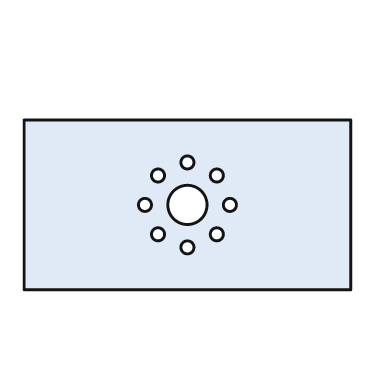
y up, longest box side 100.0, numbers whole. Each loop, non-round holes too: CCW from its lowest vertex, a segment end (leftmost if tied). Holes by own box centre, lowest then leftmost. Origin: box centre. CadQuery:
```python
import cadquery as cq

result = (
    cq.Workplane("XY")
    .moveTo(-50.0, -26.0)
    .lineTo(50.0, -26.0)
    .lineTo(50.0, 26.0)
    .lineTo(-50.0, 26.0)
    .close()
    .moveTo(0.0, -13.0)
    .circle(2.0)
    .moveTo(-9.0, -9.0)
    .circle(2.0)
    .moveTo(9.0, -9.0)
    .circle(2.0)
    .moveTo(-13.0, 0.0)
    .circle(2.0)
    .moveTo(0.0, 0.0)
    .circle(6.0)
    .moveTo(13.0, 0.0)
    .circle(2.0)
    .moveTo(-9.0, 9.0)
    .circle(2.0)
    .moveTo(9.0, 9.0)
    .circle(2.0)
    .moveTo(0.0, 13.0)
    .circle(2.0)
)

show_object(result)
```